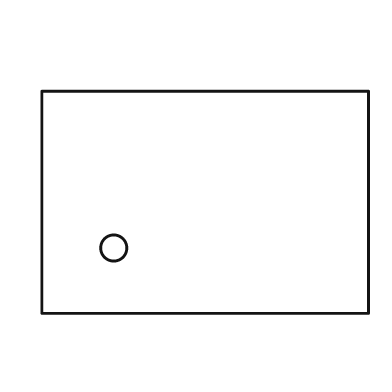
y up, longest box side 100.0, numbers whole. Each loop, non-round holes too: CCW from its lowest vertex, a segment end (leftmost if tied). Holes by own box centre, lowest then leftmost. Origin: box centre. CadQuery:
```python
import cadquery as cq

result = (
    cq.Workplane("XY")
    .moveTo(-50.0, -34.0)
    .lineTo(50.0, -34.0)
    .lineTo(50.0, 34.0)
    .lineTo(-50.0, 34.0)
    .close()
    .moveTo(-28.0, -14.0)
    .circle(4.0)
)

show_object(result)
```